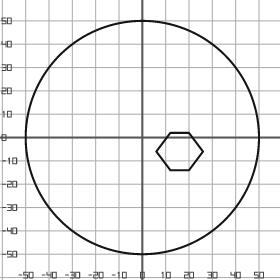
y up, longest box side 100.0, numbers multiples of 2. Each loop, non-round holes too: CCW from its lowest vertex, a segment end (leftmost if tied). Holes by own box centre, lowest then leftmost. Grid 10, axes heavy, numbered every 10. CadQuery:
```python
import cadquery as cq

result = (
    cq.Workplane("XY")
    .moveTo(0.0, 0.0)
    .circle(50.0)
    .moveTo(12.0, -14.0)
    .lineTo(20.0, -14.0)
    .lineTo(26.0, -6.0)
    .lineTo(20.0, 2.0)
    .lineTo(12.0, 2.0)
    .lineTo(6.0, -6.0)
    .close()
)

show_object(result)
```